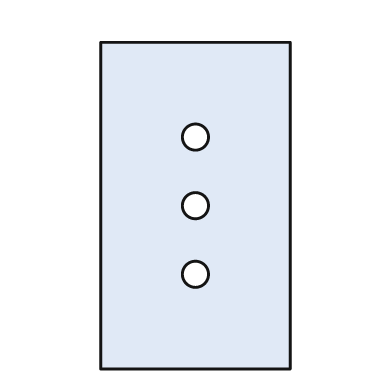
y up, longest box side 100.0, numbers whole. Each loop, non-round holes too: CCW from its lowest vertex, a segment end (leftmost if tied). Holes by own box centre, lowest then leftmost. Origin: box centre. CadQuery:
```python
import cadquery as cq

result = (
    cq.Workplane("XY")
    .moveTo(-29.0, -50.0)
    .lineTo(29.0, -50.0)
    .lineTo(29.0, 50.0)
    .lineTo(-29.0, 50.0)
    .close()
    .moveTo(0.0, -21.0)
    .circle(4.0)
    .moveTo(0.0, 0.0)
    .circle(4.0)
    .moveTo(0.0, 21.0)
    .circle(4.0)
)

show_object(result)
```